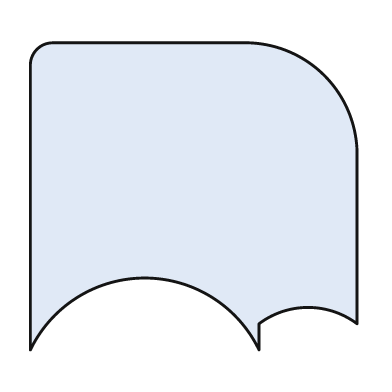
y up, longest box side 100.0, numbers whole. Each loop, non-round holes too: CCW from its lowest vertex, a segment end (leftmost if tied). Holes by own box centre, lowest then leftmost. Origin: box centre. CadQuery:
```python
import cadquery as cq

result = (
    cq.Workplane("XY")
    .moveTo(-50.0, -47.0)
    .threePointArc((-15.0, -25.0), (20.0, -47.0))
    .lineTo(20.0, -39.0)
    .threePointArc((35.0, -34.0), (50.0, -39.0))
    .lineTo(50.0, 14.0)
    .threePointArc((40.0, 37.0), (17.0, 47.0))
    .lineTo(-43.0, 47.0)
    .threePointArc((-48.0, 45.0), (-50.0, 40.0))
    .close()
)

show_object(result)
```